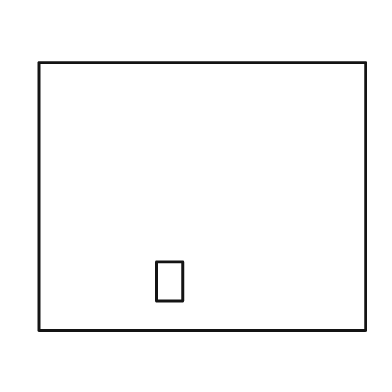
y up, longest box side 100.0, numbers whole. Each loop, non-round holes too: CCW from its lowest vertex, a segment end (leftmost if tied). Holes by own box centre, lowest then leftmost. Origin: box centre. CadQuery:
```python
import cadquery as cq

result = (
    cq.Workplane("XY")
    .moveTo(-50.0, -41.0)
    .lineTo(50.0, -41.0)
    .lineTo(50.0, 41.0)
    .lineTo(-50.0, 41.0)
    .close()
    .moveTo(-14.0, -32.0)
    .lineTo(-6.0, -32.0)
    .lineTo(-6.0, -20.0)
    .lineTo(-14.0, -20.0)
    .close()
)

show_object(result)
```